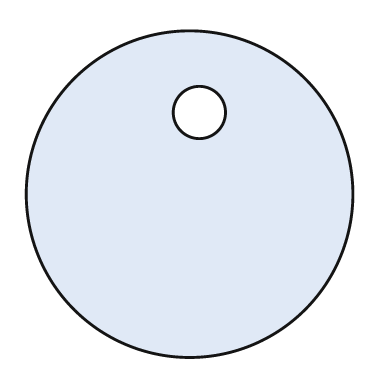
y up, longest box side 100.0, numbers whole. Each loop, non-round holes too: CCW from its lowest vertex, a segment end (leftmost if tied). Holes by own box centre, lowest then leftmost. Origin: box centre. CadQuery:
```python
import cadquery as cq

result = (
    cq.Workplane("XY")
    .moveTo(0.0, 0.0)
    .circle(50.0)
    .moveTo(3.0, 25.0)
    .circle(8.0)
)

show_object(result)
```